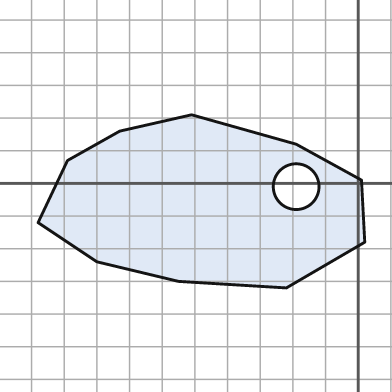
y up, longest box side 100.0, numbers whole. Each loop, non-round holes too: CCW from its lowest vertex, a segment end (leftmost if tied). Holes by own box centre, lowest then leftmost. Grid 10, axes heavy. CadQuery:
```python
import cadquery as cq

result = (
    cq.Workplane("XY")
    .moveTo(-22.0, -32.0)
    .lineTo(2.0, -18.0)
    .lineTo(1.0, 1.0)
    .lineTo(-19.0, 12.0)
    .lineTo(-51.0, 21.0)
    .lineTo(-73.0, 16.0)
    .lineTo(-89.0, 7.0)
    .lineTo(-98.0, -12.0)
    .lineTo(-80.0, -24.0)
    .lineTo(-55.0, -30.0)
    .close()
    .moveTo(-19.0, -1.0)
    .circle(7.0)
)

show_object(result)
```